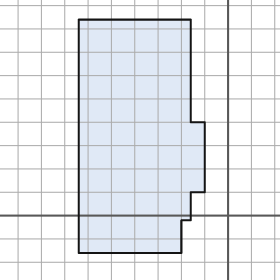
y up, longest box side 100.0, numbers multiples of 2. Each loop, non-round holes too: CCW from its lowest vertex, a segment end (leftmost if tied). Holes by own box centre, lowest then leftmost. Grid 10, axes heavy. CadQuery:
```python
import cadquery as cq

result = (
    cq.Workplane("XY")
    .moveTo(-64.0, -16.0)
    .lineTo(-20.0, -16.0)
    .lineTo(-20.0, -2.0)
    .lineTo(-16.0, -2.0)
    .lineTo(-16.0, 10.0)
    .lineTo(-10.0, 10.0)
    .lineTo(-10.0, 40.0)
    .lineTo(-16.0, 40.0)
    .lineTo(-16.0, 84.0)
    .lineTo(-64.0, 84.0)
    .close()
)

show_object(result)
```